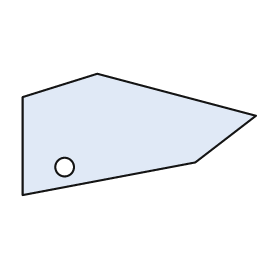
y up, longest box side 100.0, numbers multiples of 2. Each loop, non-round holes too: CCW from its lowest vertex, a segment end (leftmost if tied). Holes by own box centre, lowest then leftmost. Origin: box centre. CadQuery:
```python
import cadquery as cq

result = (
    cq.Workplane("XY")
    .moveTo(-50.0, -26.0)
    .lineTo(24.0, -12.0)
    .lineTo(50.0, 8.0)
    .lineTo(-18.0, 26.0)
    .lineTo(-50.0, 16.0)
    .close()
    .moveTo(-32.0, -14.0)
    .circle(4.0)
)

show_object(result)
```